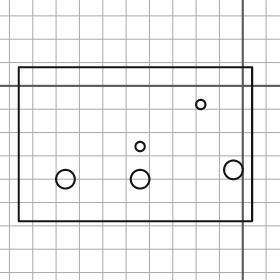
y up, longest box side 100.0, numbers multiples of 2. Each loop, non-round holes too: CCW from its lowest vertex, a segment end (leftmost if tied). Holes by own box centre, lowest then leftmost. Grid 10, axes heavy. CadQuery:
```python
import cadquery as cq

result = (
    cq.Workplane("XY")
    .moveTo(-96.0, -58.0)
    .lineTo(4.0, -58.0)
    .lineTo(4.0, 8.0)
    .lineTo(-96.0, 8.0)
    .close()
    .moveTo(-76.0, -40.0)
    .circle(4.0)
    .moveTo(-44.0, -40.0)
    .circle(4.0)
    .moveTo(-4.0, -36.0)
    .circle(4.0)
    .moveTo(-44.0, -26.0)
    .circle(2.0)
    .moveTo(-18.0, -8.0)
    .circle(2.0)
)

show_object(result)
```